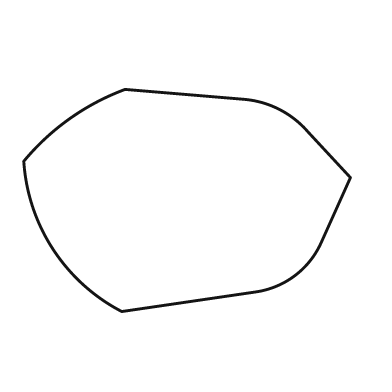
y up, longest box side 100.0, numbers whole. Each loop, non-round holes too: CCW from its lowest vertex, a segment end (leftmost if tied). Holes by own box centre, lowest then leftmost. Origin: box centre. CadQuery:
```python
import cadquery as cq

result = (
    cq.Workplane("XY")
    .moveTo(-20.0, -34.0)
    .lineTo(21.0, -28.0)
    .threePointArc((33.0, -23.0), (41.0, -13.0))
    .lineTo(50.0, 7.0)
    .lineTo(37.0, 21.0)
    .threePointArc((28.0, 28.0), (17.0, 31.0))
    .lineTo(-19.0, 34.0)
    .threePointArc((-36.0, 25.0), (-50.0, 12.0))
    .threePointArc((-41.0, -15.0), (-20.0, -34.0))
    .close()
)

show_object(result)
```